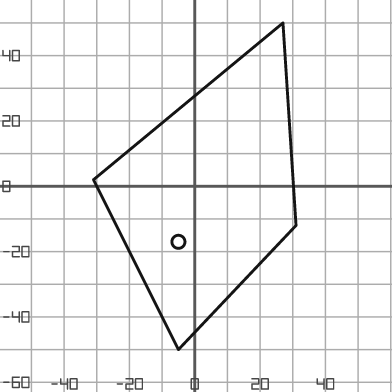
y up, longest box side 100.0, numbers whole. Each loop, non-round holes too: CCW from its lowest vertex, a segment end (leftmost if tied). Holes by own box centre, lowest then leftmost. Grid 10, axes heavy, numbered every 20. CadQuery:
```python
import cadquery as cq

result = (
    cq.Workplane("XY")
    .moveTo(-5.0, -50.0)
    .lineTo(31.0, -12.0)
    .lineTo(27.0, 50.0)
    .lineTo(-31.0, 2.0)
    .close()
    .moveTo(-5.0, -17.0)
    .circle(2.0)
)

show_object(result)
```